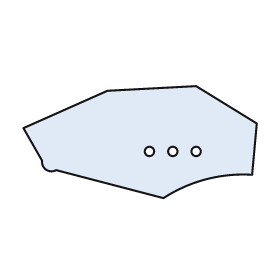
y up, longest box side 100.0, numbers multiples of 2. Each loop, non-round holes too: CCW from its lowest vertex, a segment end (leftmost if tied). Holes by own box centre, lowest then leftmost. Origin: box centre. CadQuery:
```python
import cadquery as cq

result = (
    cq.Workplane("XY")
    .moveTo(10.0, -24.0)
    .threePointArc((28.0, -16.0), (48.0, -14.0))
    .lineTo(50.0, 8.0)
    .lineTo(24.0, 24.0)
    .lineTo(-14.0, 22.0)
    .lineTo(-50.0, 6.0)
    .lineTo(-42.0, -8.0)
    .threePointArc((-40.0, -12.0), (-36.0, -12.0))
    .close()
    .moveTo(4.0, -4.0)
    .circle(2.0)
    .moveTo(14.0, -4.0)
    .circle(2.0)
    .moveTo(24.0, -4.0)
    .circle(2.0)
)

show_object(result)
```